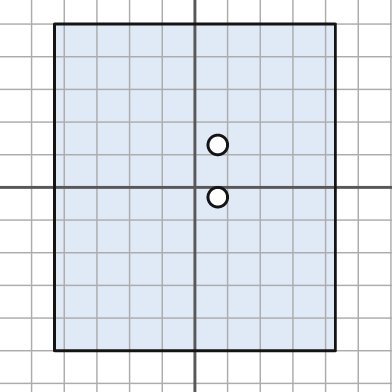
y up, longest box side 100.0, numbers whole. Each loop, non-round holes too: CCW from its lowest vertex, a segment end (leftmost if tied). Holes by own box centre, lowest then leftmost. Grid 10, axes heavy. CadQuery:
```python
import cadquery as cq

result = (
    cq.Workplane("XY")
    .moveTo(-43.0, -50.0)
    .lineTo(43.0, -50.0)
    .lineTo(43.0, 50.0)
    .lineTo(-43.0, 50.0)
    .close()
    .moveTo(7.0, -3.0)
    .circle(3.0)
    .moveTo(7.0, 13.0)
    .circle(3.0)
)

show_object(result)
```